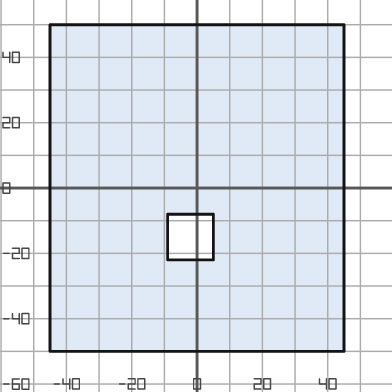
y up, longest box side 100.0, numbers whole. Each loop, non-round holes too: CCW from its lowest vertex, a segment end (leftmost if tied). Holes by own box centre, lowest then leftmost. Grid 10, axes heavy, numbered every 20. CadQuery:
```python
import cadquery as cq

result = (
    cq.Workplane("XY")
    .moveTo(-45.0, -50.0)
    .lineTo(45.0, -50.0)
    .lineTo(45.0, 50.0)
    .lineTo(-45.0, 50.0)
    .close()
    .moveTo(-9.0, -22.0)
    .lineTo(5.0, -22.0)
    .lineTo(5.0, -8.0)
    .lineTo(-9.0, -8.0)
    .close()
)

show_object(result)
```